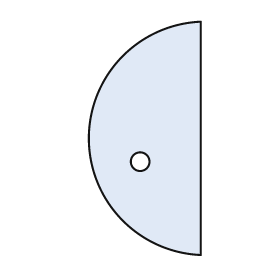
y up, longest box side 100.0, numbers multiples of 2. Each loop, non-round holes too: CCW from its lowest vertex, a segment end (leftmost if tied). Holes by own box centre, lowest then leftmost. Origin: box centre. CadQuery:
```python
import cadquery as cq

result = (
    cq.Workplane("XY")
    .moveTo(24.0, -50.0)
    .lineTo(24.0, 50.0)
    .threePointArc((-24.0, 0.0), (24.0, -50.0))
    .close()
    .moveTo(-2.0, -10.0)
    .circle(4.0)
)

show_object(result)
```